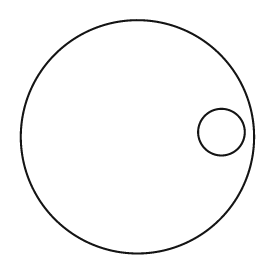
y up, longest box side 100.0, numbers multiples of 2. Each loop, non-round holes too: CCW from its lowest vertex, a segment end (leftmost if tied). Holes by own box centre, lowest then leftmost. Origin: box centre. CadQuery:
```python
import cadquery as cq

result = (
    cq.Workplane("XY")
    .moveTo(0.0, 0.0)
    .circle(50.0)
    .moveTo(36.0, 2.0)
    .circle(10.0)
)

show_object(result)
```